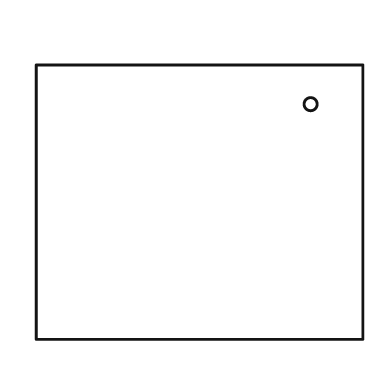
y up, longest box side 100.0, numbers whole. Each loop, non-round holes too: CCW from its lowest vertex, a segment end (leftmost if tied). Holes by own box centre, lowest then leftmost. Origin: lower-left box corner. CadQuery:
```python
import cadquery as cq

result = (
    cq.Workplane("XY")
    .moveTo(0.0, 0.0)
    .lineTo(100.0, 0.0)
    .lineTo(100.0, 84.0)
    .lineTo(0.0, 84.0)
    .close()
    .moveTo(84.0, 72.0)
    .circle(2.0)
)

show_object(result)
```